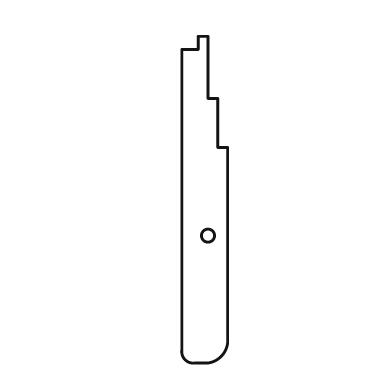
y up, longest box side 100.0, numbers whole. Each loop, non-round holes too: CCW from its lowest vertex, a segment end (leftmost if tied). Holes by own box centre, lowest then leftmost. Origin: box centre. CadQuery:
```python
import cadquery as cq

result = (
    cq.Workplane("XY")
    .moveTo(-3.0, -50.0)
    .lineTo(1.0, -50.0)
    .threePointArc((5.0, -48.0), (7.0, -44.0))
    .lineTo(7.0, 16.0)
    .lineTo(4.0, 16.0)
    .lineTo(4.0, 31.0)
    .lineTo(1.0, 31.0)
    .lineTo(1.0, 50.0)
    .lineTo(-2.0, 50.0)
    .lineTo(-2.0, 46.0)
    .lineTo(-7.0, 46.0)
    .lineTo(-7.0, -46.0)
    .threePointArc((-6.0, -49.0), (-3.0, -50.0))
    .close()
    .moveTo(1.0, -11.0)
    .circle(2.0)
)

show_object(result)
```